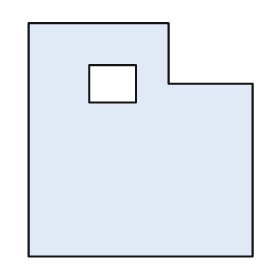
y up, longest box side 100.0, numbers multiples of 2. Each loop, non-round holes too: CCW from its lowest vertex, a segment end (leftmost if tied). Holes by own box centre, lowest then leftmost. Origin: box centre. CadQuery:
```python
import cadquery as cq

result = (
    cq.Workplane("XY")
    .moveTo(-48.0, -50.0)
    .lineTo(48.0, -50.0)
    .lineTo(48.0, 24.0)
    .lineTo(12.0, 24.0)
    .lineTo(12.0, 50.0)
    .lineTo(-48.0, 50.0)
    .close()
    .moveTo(-22.0, 16.0)
    .lineTo(-2.0, 16.0)
    .lineTo(-2.0, 32.0)
    .lineTo(-22.0, 32.0)
    .close()
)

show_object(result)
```